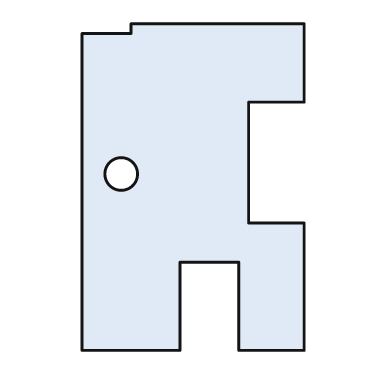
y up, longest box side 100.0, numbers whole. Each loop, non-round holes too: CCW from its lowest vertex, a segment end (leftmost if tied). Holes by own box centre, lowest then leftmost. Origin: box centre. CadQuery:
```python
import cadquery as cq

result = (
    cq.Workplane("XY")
    .moveTo(-34.0, -50.0)
    .lineTo(-4.0, -50.0)
    .lineTo(-4.0, -23.0)
    .lineTo(14.0, -23.0)
    .lineTo(14.0, -50.0)
    .lineTo(34.0, -50.0)
    .lineTo(34.0, -11.0)
    .lineTo(17.0, -11.0)
    .lineTo(17.0, 26.0)
    .lineTo(34.0, 26.0)
    .lineTo(34.0, 50.0)
    .lineTo(-19.0, 50.0)
    .lineTo(-19.0, 47.0)
    .lineTo(-34.0, 47.0)
    .close()
    .moveTo(-22.0, 4.0)
    .circle(5.0)
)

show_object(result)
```